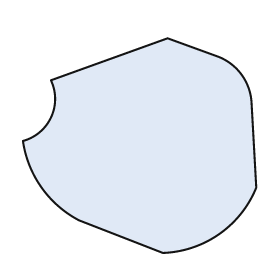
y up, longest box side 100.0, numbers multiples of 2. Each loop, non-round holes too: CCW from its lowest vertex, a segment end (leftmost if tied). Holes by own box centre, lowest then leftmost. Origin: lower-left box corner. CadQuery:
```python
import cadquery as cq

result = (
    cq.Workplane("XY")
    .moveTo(60.0, 0.0)
    .threePointArc((84.0, 8.0), (100.0, 28.0))
    .lineTo(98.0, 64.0)
    .threePointArc((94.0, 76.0), (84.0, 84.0))
    .lineTo(62.0, 92.0)
    .lineTo(12.0, 74.0)
    .threePointArc((12.0, 58.0), (0.0, 48.0))
    .threePointArc((8.0, 28.0), (24.0, 14.0))
    .close()
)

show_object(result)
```